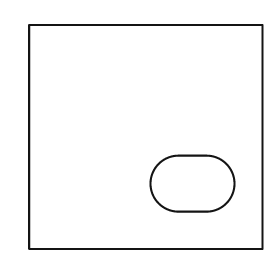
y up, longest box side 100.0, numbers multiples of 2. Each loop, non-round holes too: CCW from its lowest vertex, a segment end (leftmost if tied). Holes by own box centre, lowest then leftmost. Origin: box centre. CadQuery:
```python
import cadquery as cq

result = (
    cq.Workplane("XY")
    .moveTo(-50.0, -48.0)
    .lineTo(50.0, -48.0)
    .lineTo(50.0, 48.0)
    .lineTo(-50.0, 48.0)
    .close()
    .moveTo(14.0, -32.0)
    .lineTo(26.0, -32.0)
    .threePointArc((38.0, -20.0), (26.0, -8.0))
    .lineTo(14.0, -8.0)
    .threePointArc((2.0, -20.0), (14.0, -32.0))
    .close()
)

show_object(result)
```